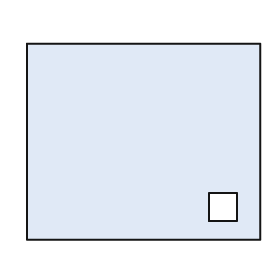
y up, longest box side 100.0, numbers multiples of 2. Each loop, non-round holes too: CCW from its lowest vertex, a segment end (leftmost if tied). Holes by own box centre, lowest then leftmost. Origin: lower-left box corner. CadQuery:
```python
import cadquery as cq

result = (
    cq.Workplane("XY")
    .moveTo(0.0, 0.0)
    .lineTo(100.0, 0.0)
    .lineTo(100.0, 84.0)
    .lineTo(0.0, 84.0)
    .close()
    .moveTo(78.0, 8.0)
    .lineTo(90.0, 8.0)
    .lineTo(90.0, 20.0)
    .lineTo(78.0, 20.0)
    .close()
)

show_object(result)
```